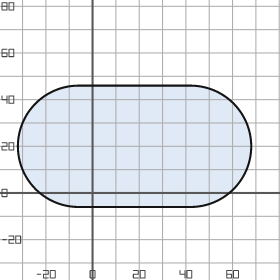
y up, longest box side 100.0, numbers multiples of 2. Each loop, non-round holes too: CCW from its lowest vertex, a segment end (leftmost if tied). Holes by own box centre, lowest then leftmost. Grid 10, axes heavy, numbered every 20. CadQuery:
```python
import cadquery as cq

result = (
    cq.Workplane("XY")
    .moveTo(-6.0, -6.0)
    .lineTo(42.0, -6.0)
    .threePointArc((68.0, 20.0), (42.0, 46.0))
    .lineTo(-6.0, 46.0)
    .threePointArc((-32.0, 20.0), (-6.0, -6.0))
    .close()
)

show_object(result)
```